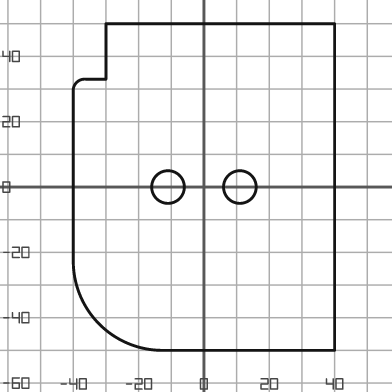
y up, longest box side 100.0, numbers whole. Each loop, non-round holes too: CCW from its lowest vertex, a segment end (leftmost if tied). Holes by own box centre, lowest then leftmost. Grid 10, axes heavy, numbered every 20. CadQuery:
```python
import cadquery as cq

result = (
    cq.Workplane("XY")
    .moveTo(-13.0, -50.0)
    .lineTo(40.0, -50.0)
    .lineTo(40.0, 50.0)
    .lineTo(-30.0, 50.0)
    .lineTo(-30.0, 33.0)
    .lineTo(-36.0, 33.0)
    .threePointArc((-39.0, 32.0), (-40.0, 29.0))
    .lineTo(-40.0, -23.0)
    .threePointArc((-32.0, -42.0), (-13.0, -50.0))
    .close()
    .moveTo(-11.0, 0.0)
    .circle(5.0)
    .moveTo(11.0, 0.0)
    .circle(5.0)
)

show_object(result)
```